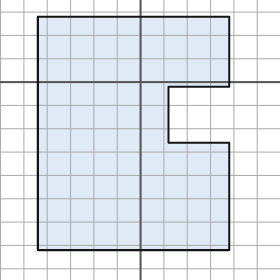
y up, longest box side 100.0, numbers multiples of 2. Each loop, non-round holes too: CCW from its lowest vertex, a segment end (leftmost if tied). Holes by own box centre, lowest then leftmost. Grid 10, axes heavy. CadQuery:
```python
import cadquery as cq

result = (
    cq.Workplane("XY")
    .moveTo(-44.0, -72.0)
    .lineTo(38.0, -72.0)
    .lineTo(38.0, -26.0)
    .lineTo(12.0, -26.0)
    .lineTo(12.0, -2.0)
    .lineTo(38.0, -2.0)
    .lineTo(38.0, 28.0)
    .lineTo(-44.0, 28.0)
    .close()
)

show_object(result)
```